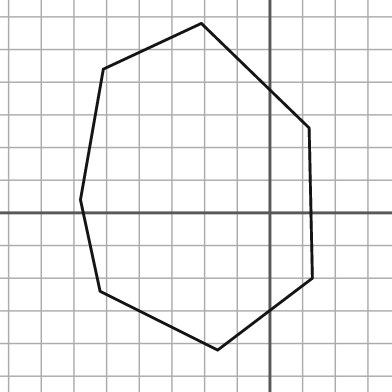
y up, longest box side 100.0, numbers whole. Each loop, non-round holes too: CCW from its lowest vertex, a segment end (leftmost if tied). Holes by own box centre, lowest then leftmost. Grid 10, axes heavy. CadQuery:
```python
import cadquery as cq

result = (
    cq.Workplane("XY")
    .moveTo(-16.0, -42.0)
    .lineTo(13.0, -20.0)
    .lineTo(12.0, 26.0)
    .lineTo(-21.0, 58.0)
    .lineTo(-51.0, 44.0)
    .lineTo(-58.0, 4.0)
    .lineTo(-52.0, -24.0)
    .close()
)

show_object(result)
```